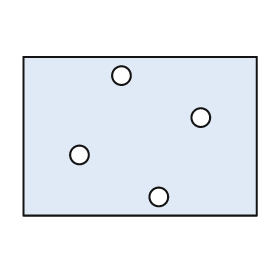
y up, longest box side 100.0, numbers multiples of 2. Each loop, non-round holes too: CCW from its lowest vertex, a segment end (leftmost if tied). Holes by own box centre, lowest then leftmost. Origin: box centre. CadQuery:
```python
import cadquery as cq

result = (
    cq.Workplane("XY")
    .moveTo(-50.0, -34.0)
    .lineTo(50.0, -34.0)
    .lineTo(50.0, 34.0)
    .lineTo(-50.0, 34.0)
    .close()
    .moveTo(8.0, -26.0)
    .circle(4.0)
    .moveTo(-26.0, -8.0)
    .circle(4.0)
    .moveTo(26.0, 8.0)
    .circle(4.0)
    .moveTo(-8.0, 26.0)
    .circle(4.0)
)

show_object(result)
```